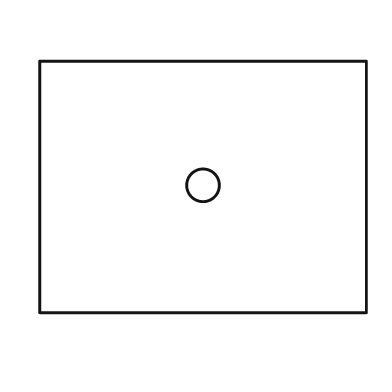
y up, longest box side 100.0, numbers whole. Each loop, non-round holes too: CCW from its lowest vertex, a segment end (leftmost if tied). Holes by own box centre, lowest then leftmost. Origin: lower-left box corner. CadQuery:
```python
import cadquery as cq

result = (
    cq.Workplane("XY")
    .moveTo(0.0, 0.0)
    .lineTo(100.0, 0.0)
    .lineTo(100.0, 77.0)
    .lineTo(0.0, 77.0)
    .close()
    .moveTo(50.0, 39.0)
    .circle(5.0)
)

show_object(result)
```